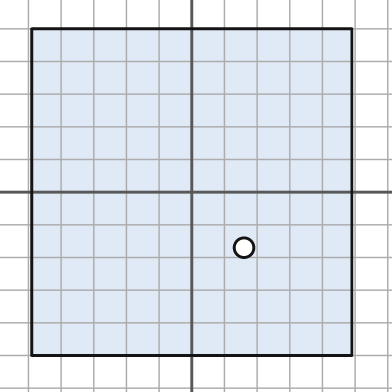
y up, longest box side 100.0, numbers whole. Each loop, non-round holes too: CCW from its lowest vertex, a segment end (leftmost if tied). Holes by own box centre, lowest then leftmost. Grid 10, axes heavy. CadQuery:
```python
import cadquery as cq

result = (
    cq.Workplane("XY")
    .moveTo(-49.0, -50.0)
    .lineTo(49.0, -50.0)
    .lineTo(49.0, 50.0)
    .lineTo(-49.0, 50.0)
    .close()
    .moveTo(16.0, -17.0)
    .circle(3.0)
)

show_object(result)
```